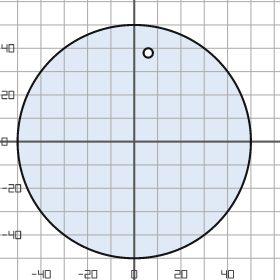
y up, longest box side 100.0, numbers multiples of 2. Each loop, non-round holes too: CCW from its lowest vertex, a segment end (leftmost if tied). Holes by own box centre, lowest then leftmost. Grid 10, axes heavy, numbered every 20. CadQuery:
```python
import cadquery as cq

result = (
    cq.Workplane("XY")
    .moveTo(0.0, 0.0)
    .circle(50.0)
    .moveTo(6.0, 38.0)
    .circle(2.0)
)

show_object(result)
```